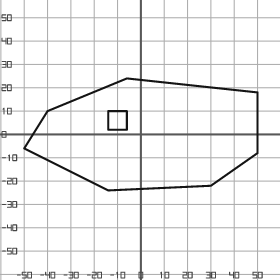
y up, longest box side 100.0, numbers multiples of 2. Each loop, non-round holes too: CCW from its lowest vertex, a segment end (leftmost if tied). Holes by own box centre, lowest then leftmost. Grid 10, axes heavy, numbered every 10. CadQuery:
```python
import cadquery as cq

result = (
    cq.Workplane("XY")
    .moveTo(-14.0, -24.0)
    .lineTo(30.0, -22.0)
    .lineTo(50.0, -8.0)
    .lineTo(50.0, 18.0)
    .lineTo(-6.0, 24.0)
    .lineTo(-40.0, 10.0)
    .lineTo(-50.0, -6.0)
    .close()
    .moveTo(-14.0, 2.0)
    .lineTo(-6.0, 2.0)
    .lineTo(-6.0, 10.0)
    .lineTo(-14.0, 10.0)
    .close()
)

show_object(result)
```